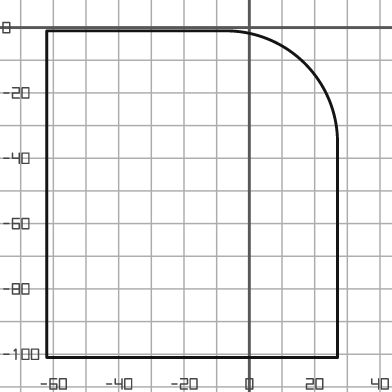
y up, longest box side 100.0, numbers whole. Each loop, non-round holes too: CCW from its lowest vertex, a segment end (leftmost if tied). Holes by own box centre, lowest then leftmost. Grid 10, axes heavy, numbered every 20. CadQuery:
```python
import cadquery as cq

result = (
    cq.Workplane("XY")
    .moveTo(-62.0, -101.0)
    .lineTo(27.0, -101.0)
    .lineTo(27.0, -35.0)
    .threePointArc((17.0, -11.0), (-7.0, -1.0))
    .lineTo(-62.0, -1.0)
    .close()
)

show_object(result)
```